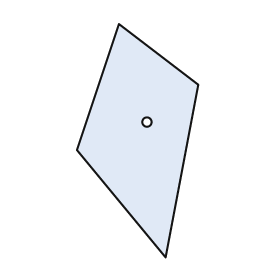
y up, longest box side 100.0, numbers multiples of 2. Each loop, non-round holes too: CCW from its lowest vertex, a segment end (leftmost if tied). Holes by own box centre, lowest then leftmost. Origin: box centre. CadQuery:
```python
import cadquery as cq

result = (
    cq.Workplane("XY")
    .moveTo(12.0, -50.0)
    .lineTo(26.0, 24.0)
    .lineTo(-8.0, 50.0)
    .lineTo(-26.0, -4.0)
    .close()
    .moveTo(4.0, 8.0)
    .circle(2.0)
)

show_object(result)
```